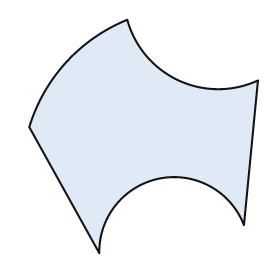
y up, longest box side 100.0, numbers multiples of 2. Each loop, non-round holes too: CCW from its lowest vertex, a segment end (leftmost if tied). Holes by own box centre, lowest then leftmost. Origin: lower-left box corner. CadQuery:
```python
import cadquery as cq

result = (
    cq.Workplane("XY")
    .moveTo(30.0, 0.0)
    .threePointArc((56.0, 32.0), (92.0, 12.0))
    .lineTo(98.0, 74.0)
    .threePointArc((64.0, 74.0), (42.0, 100.0))
    .threePointArc((16.0, 82.0), (0.0, 54.0))
    .close()
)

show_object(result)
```